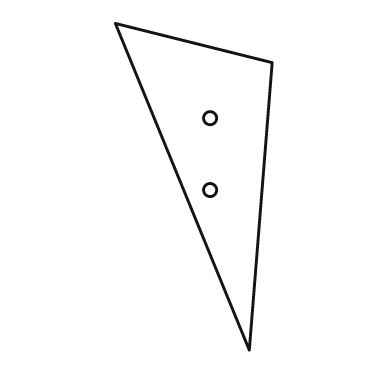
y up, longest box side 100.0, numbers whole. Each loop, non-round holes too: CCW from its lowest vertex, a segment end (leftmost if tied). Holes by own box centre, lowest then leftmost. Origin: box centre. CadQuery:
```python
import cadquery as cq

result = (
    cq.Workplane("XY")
    .moveTo(17.0, -50.0)
    .lineTo(24.0, 38.0)
    .lineTo(-24.0, 50.0)
    .close()
    .moveTo(5.0, -1.0)
    .circle(2.0)
    .moveTo(5.0, 21.0)
    .circle(2.0)
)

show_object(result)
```